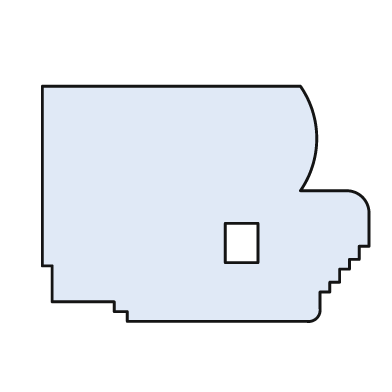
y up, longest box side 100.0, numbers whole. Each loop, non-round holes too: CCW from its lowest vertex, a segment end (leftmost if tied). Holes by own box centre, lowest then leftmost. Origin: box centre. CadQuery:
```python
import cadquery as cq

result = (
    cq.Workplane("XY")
    .moveTo(-24.0, -36.0)
    .lineTo(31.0, -36.0)
    .threePointArc((34.0, -35.0), (35.0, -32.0))
    .lineTo(35.0, -27.0)
    .lineTo(38.0, -27.0)
    .lineTo(38.0, -24.0)
    .lineTo(41.0, -24.0)
    .lineTo(41.0, -20.0)
    .lineTo(44.0, -20.0)
    .lineTo(44.0, -17.0)
    .lineTo(47.0, -17.0)
    .lineTo(47.0, -13.0)
    .lineTo(50.0, -13.0)
    .lineTo(50.0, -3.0)
    .threePointArc((48.0, 2.0), (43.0, 4.0))
    .lineTo(29.0, 4.0)
    .threePointArc((34.0, 20.0), (29.0, 36.0))
    .lineTo(-50.0, 36.0)
    .lineTo(-50.0, -19.0)
    .lineTo(-47.0, -19.0)
    .lineTo(-47.0, -30.0)
    .lineTo(-28.0, -30.0)
    .lineTo(-28.0, -33.0)
    .lineTo(-24.0, -33.0)
    .close()
    .moveTo(6.0, -18.0)
    .lineTo(16.0, -18.0)
    .lineTo(16.0, -6.0)
    .lineTo(6.0, -6.0)
    .close()
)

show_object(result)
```